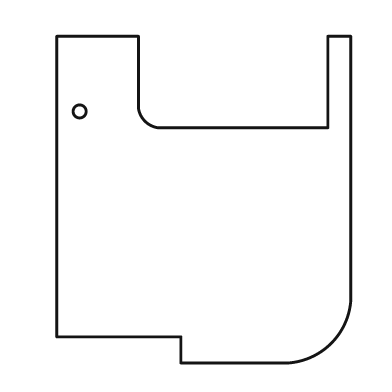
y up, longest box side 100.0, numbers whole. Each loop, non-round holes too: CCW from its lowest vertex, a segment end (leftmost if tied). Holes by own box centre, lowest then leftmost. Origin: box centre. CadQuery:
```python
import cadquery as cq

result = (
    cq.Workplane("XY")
    .moveTo(-7.0, -50.0)
    .lineTo(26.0, -50.0)
    .threePointArc((39.0, -44.0), (45.0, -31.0))
    .lineTo(45.0, 50.0)
    .lineTo(38.0, 50.0)
    .lineTo(38.0, 22.0)
    .lineTo(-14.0, 22.0)
    .threePointArc((-18.0, 24.0), (-20.0, 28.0))
    .lineTo(-20.0, 50.0)
    .lineTo(-45.0, 50.0)
    .lineTo(-45.0, -42.0)
    .lineTo(-7.0, -42.0)
    .close()
    .moveTo(-38.0, 27.0)
    .circle(2.0)
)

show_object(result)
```